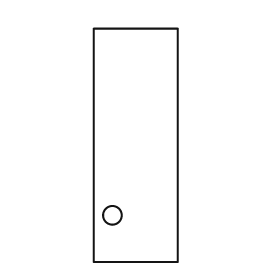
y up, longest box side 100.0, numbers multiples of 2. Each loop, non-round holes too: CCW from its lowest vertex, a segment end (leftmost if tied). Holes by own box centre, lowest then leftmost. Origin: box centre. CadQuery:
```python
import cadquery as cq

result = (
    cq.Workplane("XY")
    .moveTo(-18.0, -50.0)
    .lineTo(18.0, -50.0)
    .lineTo(18.0, 50.0)
    .lineTo(-18.0, 50.0)
    .close()
    .moveTo(-10.0, -30.0)
    .circle(4.0)
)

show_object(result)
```